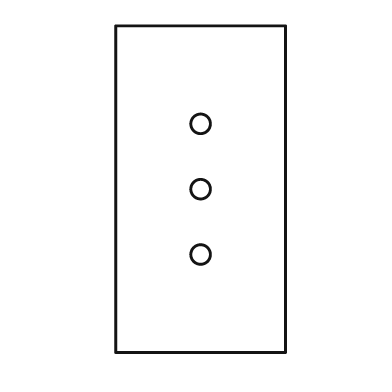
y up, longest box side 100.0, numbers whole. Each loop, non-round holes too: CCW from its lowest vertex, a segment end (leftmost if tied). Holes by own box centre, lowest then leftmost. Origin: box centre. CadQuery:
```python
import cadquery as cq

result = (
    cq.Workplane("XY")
    .moveTo(-26.0, -50.0)
    .lineTo(26.0, -50.0)
    .lineTo(26.0, 50.0)
    .lineTo(-26.0, 50.0)
    .close()
    .moveTo(0.0, -20.0)
    .circle(3.0)
    .moveTo(0.0, 0.0)
    .circle(3.0)
    .moveTo(0.0, 20.0)
    .circle(3.0)
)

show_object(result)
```